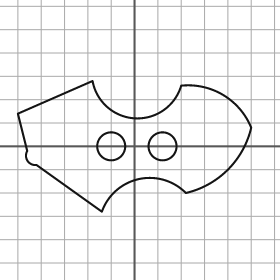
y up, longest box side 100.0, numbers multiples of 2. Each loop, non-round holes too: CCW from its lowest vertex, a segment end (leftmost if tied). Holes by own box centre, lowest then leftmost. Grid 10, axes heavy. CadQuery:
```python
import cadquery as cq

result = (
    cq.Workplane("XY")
    .moveTo(-14.0, -28.0)
    .threePointArc((2.0, -14.0), (22.0, -20.0))
    .threePointArc((40.0, -10.0), (50.0, 8.0))
    .threePointArc((38.0, 22.0), (20.0, 26.0))
    .threePointArc((0.0, 12.0), (-18.0, 28.0))
    .lineTo(-50.0, 14.0)
    .lineTo(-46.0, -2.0)
    .threePointArc((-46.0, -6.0), (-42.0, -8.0))
    .close()
    .moveTo(-10.0, 0.0)
    .circle(6.0)
    .moveTo(12.0, 0.0)
    .circle(6.0)
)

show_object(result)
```